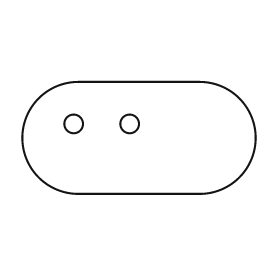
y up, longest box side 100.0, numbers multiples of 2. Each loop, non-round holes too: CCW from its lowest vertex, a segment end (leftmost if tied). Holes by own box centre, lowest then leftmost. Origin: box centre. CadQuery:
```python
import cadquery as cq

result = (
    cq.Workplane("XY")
    .moveTo(-26.0, -24.0)
    .lineTo(26.0, -24.0)
    .threePointArc((50.0, 0.0), (26.0, 24.0))
    .lineTo(-26.0, 24.0)
    .threePointArc((-50.0, 0.0), (-26.0, -24.0))
    .close()
    .moveTo(-28.0, 6.0)
    .circle(4.0)
    .moveTo(-4.0, 6.0)
    .circle(4.0)
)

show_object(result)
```